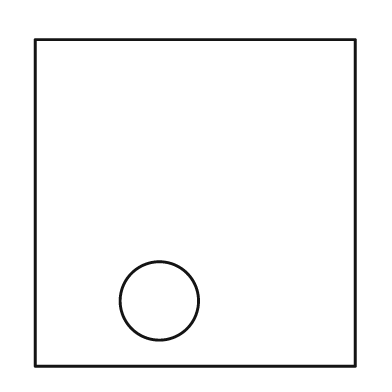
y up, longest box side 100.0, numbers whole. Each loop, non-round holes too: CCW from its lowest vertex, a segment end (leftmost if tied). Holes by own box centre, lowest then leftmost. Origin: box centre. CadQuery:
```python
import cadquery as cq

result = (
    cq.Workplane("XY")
    .moveTo(-49.0, -50.0)
    .lineTo(49.0, -50.0)
    .lineTo(49.0, 50.0)
    .lineTo(-49.0, 50.0)
    .close()
    .moveTo(-11.0, -30.0)
    .circle(12.0)
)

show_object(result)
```